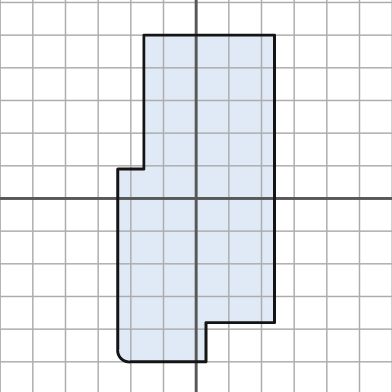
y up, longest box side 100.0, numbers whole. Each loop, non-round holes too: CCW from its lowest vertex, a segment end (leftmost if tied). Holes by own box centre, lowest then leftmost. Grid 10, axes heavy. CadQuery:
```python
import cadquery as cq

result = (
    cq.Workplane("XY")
    .moveTo(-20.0, -50.0)
    .lineTo(3.0, -50.0)
    .lineTo(3.0, -38.0)
    .lineTo(24.0, -38.0)
    .lineTo(24.0, 50.0)
    .lineTo(-16.0, 50.0)
    .lineTo(-16.0, 9.0)
    .lineTo(-24.0, 9.0)
    .lineTo(-24.0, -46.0)
    .threePointArc((-23.0, -49.0), (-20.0, -50.0))
    .close()
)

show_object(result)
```